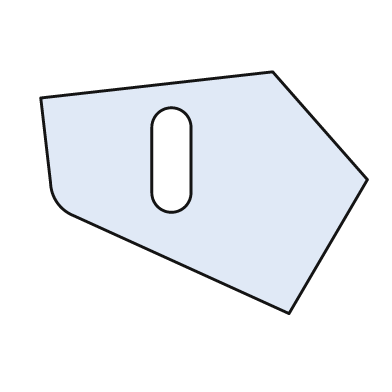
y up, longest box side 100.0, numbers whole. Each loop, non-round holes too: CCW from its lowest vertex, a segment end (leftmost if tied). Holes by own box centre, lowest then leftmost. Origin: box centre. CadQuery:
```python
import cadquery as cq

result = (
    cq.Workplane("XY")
    .moveTo(26.0, -37.0)
    .lineTo(50.0, 4.0)
    .lineTo(21.0, 37.0)
    .lineTo(-50.0, 29.0)
    .lineTo(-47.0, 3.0)
    .threePointArc((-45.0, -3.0), (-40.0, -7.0))
    .close()
    .moveTo(-16.0, 0.0)
    .threePointArc((-10.0, -6.0), (-4.0, 0.0))
    .lineTo(-4.0, 20.0)
    .threePointArc((-10.0, 26.0), (-16.0, 20.0))
    .close()
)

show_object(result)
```